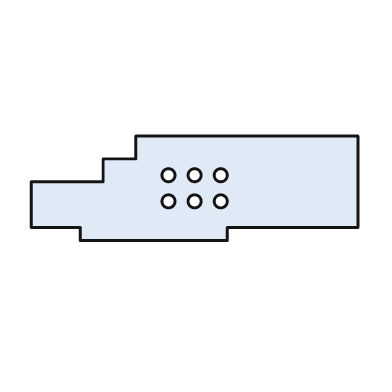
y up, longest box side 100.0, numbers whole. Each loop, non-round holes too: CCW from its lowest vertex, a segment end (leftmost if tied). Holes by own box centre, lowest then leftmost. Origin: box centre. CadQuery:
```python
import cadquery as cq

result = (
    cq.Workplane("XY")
    .moveTo(-35.0, -16.0)
    .lineTo(10.0, -16.0)
    .lineTo(10.0, -12.0)
    .lineTo(50.0, -12.0)
    .lineTo(50.0, 16.0)
    .lineTo(-18.0, 16.0)
    .lineTo(-18.0, 9.0)
    .lineTo(-28.0, 9.0)
    .lineTo(-28.0, 2.0)
    .lineTo(-50.0, 2.0)
    .lineTo(-50.0, -12.0)
    .lineTo(-35.0, -12.0)
    .close()
    .moveTo(-8.0, -4.0)
    .circle(2.0)
    .moveTo(0.0, -4.0)
    .circle(2.0)
    .moveTo(8.0, -4.0)
    .circle(2.0)
    .moveTo(-8.0, 4.0)
    .circle(2.0)
    .moveTo(0.0, 4.0)
    .circle(2.0)
    .moveTo(8.0, 4.0)
    .circle(2.0)
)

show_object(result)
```